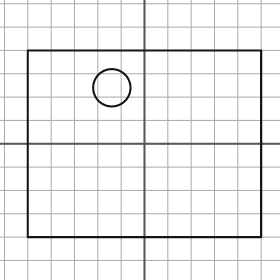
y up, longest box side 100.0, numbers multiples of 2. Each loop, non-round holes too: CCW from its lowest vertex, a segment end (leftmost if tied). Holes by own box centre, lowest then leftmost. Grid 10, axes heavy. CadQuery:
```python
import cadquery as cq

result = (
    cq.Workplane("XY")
    .moveTo(-50.0, -40.0)
    .lineTo(50.0, -40.0)
    .lineTo(50.0, 40.0)
    .lineTo(-50.0, 40.0)
    .close()
    .moveTo(-14.0, 24.0)
    .circle(8.0)
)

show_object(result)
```